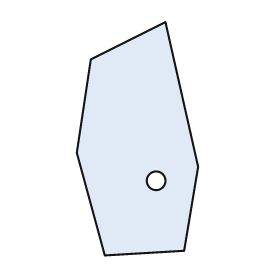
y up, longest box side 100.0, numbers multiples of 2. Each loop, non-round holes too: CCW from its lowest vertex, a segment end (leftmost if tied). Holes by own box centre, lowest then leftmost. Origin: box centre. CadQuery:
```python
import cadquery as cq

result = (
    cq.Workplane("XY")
    .moveTo(-14.0, -50.0)
    .lineTo(20.0, -48.0)
    .lineTo(26.0, -12.0)
    .lineTo(12.0, 50.0)
    .lineTo(-20.0, 34.0)
    .lineTo(-26.0, -6.0)
    .close()
    .moveTo(8.0, -18.0)
    .circle(4.0)
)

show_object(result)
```